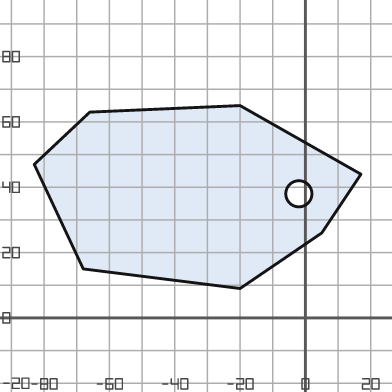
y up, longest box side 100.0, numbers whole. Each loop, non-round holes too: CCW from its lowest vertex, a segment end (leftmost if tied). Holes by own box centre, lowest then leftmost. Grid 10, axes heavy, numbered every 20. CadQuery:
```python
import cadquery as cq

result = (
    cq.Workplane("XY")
    .moveTo(-20.0, 9.0)
    .lineTo(5.0, 26.0)
    .lineTo(17.0, 44.0)
    .lineTo(-20.0, 65.0)
    .lineTo(-66.0, 63.0)
    .lineTo(-83.0, 47.0)
    .lineTo(-68.0, 15.0)
    .close()
    .moveTo(-2.0, 38.0)
    .circle(4.0)
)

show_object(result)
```